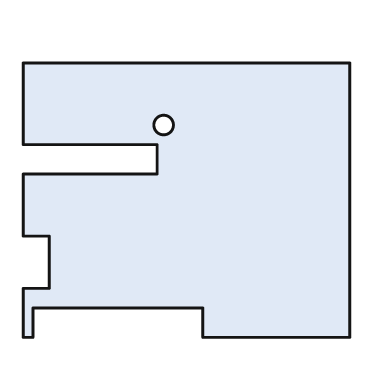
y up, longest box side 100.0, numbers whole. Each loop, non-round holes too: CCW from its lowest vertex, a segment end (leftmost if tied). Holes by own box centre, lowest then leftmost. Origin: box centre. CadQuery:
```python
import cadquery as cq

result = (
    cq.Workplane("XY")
    .moveTo(-50.0, -42.0)
    .lineTo(-47.0, -42.0)
    .lineTo(-47.0, -33.0)
    .lineTo(5.0, -33.0)
    .lineTo(5.0, -42.0)
    .lineTo(50.0, -42.0)
    .lineTo(50.0, 42.0)
    .lineTo(-50.0, 42.0)
    .lineTo(-50.0, 17.0)
    .lineTo(-9.0, 17.0)
    .lineTo(-9.0, 8.0)
    .lineTo(-50.0, 8.0)
    .lineTo(-50.0, -11.0)
    .lineTo(-42.0, -11.0)
    .lineTo(-42.0, -27.0)
    .lineTo(-50.0, -27.0)
    .close()
    .moveTo(-7.0, 23.0)
    .circle(3.0)
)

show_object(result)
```